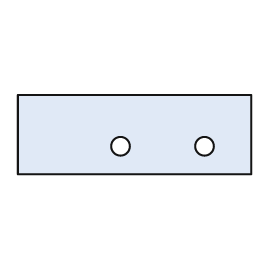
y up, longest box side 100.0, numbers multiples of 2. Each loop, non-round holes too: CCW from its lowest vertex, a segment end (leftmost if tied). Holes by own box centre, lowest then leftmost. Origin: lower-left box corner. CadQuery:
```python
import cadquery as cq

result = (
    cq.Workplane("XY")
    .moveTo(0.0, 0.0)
    .lineTo(100.0, 0.0)
    .lineTo(100.0, 34.0)
    .lineTo(0.0, 34.0)
    .close()
    .moveTo(44.0, 12.0)
    .circle(4.0)
    .moveTo(80.0, 12.0)
    .circle(4.0)
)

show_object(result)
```